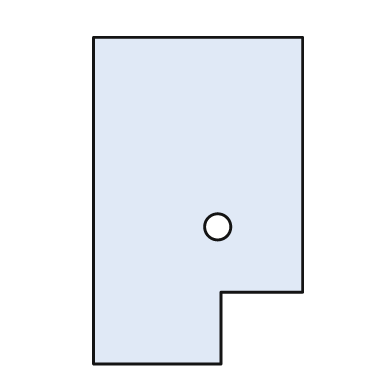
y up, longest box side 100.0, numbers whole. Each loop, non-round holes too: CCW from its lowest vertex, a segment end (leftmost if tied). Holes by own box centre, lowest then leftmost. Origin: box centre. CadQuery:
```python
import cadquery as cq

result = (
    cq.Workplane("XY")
    .moveTo(-32.0, -50.0)
    .lineTo(7.0, -50.0)
    .lineTo(7.0, -28.0)
    .lineTo(32.0, -28.0)
    .lineTo(32.0, 50.0)
    .lineTo(-32.0, 50.0)
    .close()
    .moveTo(6.0, -8.0)
    .circle(4.0)
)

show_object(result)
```